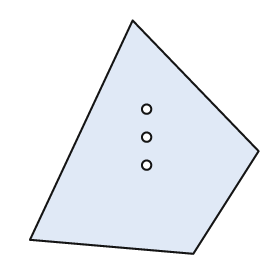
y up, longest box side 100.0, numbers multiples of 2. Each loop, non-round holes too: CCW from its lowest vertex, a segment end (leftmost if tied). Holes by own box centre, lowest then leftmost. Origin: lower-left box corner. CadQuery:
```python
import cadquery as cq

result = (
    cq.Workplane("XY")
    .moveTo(70.0, 0.0)
    .lineTo(98.0, 44.0)
    .lineTo(44.0, 100.0)
    .lineTo(0.0, 6.0)
    .close()
    .moveTo(50.0, 38.0)
    .circle(2.0)
    .moveTo(50.0, 50.0)
    .circle(2.0)
    .moveTo(50.0, 62.0)
    .circle(2.0)
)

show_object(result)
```